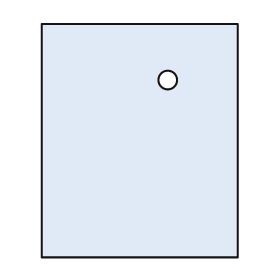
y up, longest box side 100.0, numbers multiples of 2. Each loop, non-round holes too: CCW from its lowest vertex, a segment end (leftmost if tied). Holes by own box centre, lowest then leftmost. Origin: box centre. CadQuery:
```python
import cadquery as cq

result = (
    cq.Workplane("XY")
    .moveTo(-42.0, -50.0)
    .lineTo(42.0, -50.0)
    .lineTo(42.0, 50.0)
    .lineTo(-42.0, 50.0)
    .close()
    .moveTo(12.0, 26.0)
    .circle(4.0)
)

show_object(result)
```